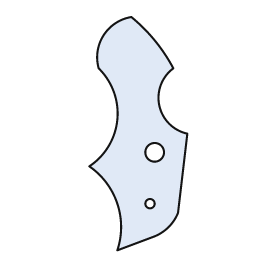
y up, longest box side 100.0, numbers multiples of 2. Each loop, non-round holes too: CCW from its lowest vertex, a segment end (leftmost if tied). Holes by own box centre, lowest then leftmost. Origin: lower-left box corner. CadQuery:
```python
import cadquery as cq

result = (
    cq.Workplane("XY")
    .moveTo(12.0, 0.0)
    .lineTo(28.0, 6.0)
    .threePointArc((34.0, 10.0), (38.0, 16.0))
    .lineTo(42.0, 50.0)
    .threePointArc((30.0, 62.0), (36.0, 78.0))
    .threePointArc((28.0, 90.0), (18.0, 100.0))
    .threePointArc((6.0, 92.0), (4.0, 78.0))
    .threePointArc((12.0, 56.0), (0.0, 36.0))
    .threePointArc((12.0, 20.0), (12.0, 0.0))
    .close()
    .moveTo(26.0, 20.0)
    .circle(2.0)
    .moveTo(28.0, 42.0)
    .circle(4.0)
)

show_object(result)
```